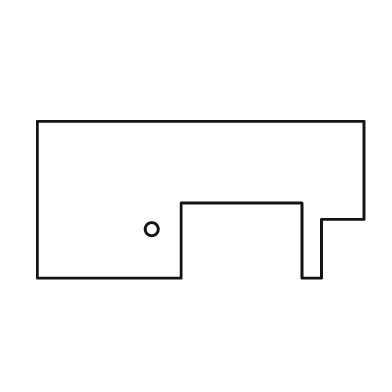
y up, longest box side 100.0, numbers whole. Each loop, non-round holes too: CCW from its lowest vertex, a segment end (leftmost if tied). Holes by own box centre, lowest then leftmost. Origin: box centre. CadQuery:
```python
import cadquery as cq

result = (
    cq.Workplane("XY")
    .moveTo(-50.0, -24.0)
    .lineTo(-6.0, -24.0)
    .lineTo(-6.0, -1.0)
    .lineTo(31.0, -1.0)
    .lineTo(31.0, -24.0)
    .lineTo(37.0, -24.0)
    .lineTo(37.0, -6.0)
    .lineTo(50.0, -6.0)
    .lineTo(50.0, 24.0)
    .lineTo(-50.0, 24.0)
    .close()
    .moveTo(-15.0, -9.0)
    .circle(2.0)
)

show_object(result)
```